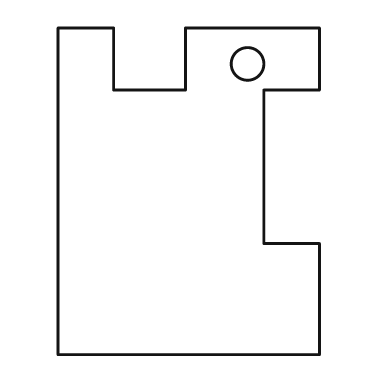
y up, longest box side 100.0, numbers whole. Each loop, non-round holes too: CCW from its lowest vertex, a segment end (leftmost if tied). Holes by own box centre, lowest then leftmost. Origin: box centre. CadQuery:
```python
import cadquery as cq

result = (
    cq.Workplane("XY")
    .moveTo(-40.0, -50.0)
    .lineTo(40.0, -50.0)
    .lineTo(40.0, -16.0)
    .lineTo(23.0, -16.0)
    .lineTo(23.0, 31.0)
    .lineTo(40.0, 31.0)
    .lineTo(40.0, 50.0)
    .lineTo(-1.0, 50.0)
    .lineTo(-1.0, 31.0)
    .lineTo(-23.0, 31.0)
    .lineTo(-23.0, 50.0)
    .lineTo(-40.0, 50.0)
    .close()
    .moveTo(18.0, 39.0)
    .circle(5.0)
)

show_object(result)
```